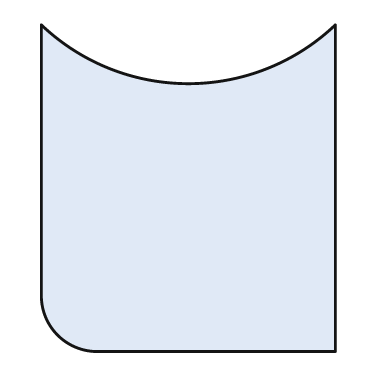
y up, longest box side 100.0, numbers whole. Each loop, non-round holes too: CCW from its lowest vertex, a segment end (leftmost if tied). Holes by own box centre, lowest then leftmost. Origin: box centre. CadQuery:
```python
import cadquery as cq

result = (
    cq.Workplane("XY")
    .moveTo(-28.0, -50.0)
    .lineTo(45.0, -50.0)
    .lineTo(45.0, 50.0)
    .threePointArc((0.0, 32.0), (-45.0, 50.0))
    .lineTo(-45.0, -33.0)
    .threePointArc((-40.0, -45.0), (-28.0, -50.0))
    .close()
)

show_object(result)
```